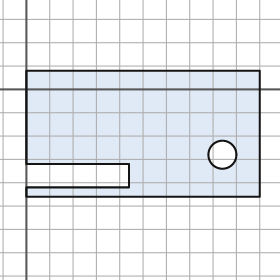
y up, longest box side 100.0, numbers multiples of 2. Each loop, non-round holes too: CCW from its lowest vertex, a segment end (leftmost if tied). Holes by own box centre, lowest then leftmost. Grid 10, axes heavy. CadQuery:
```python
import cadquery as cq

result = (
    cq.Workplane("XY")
    .moveTo(0.0, -46.0)
    .lineTo(100.0, -46.0)
    .lineTo(100.0, 8.0)
    .lineTo(0.0, 8.0)
    .lineTo(0.0, -32.0)
    .lineTo(44.0, -32.0)
    .lineTo(44.0, -42.0)
    .lineTo(0.0, -42.0)
    .close()
    .moveTo(84.0, -28.0)
    .circle(6.0)
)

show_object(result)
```